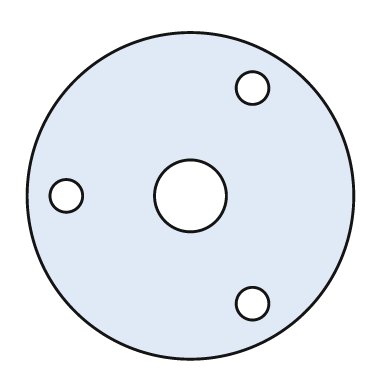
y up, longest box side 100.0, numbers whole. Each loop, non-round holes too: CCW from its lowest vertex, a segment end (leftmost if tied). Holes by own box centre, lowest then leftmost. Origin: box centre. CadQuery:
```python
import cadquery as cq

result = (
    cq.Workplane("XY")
    .moveTo(0.0, 0.0)
    .circle(50.0)
    .moveTo(19.0, -33.0)
    .circle(5.0)
    .moveTo(-38.0, 0.0)
    .circle(5.0)
    .moveTo(0.0, 0.0)
    .circle(11.0)
    .moveTo(19.0, 33.0)
    .circle(5.0)
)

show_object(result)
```